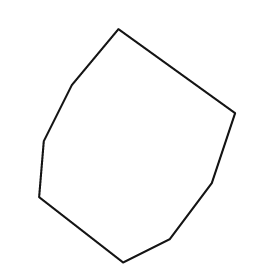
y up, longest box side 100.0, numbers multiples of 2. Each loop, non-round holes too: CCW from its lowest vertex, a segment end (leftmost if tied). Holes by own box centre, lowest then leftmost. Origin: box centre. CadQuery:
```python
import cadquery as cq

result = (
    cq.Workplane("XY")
    .moveTo(-6.0, -50.0)
    .lineTo(14.0, -40.0)
    .lineTo(32.0, -16.0)
    .lineTo(42.0, 14.0)
    .lineTo(-8.0, 50.0)
    .lineTo(-28.0, 26.0)
    .lineTo(-40.0, 2.0)
    .lineTo(-42.0, -22.0)
    .close()
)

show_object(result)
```